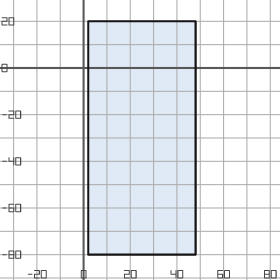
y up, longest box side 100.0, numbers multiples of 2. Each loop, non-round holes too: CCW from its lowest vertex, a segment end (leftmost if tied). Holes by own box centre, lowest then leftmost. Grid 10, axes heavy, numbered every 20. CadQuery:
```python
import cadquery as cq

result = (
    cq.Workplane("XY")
    .moveTo(2.0, -80.0)
    .lineTo(48.0, -80.0)
    .lineTo(48.0, 20.0)
    .lineTo(2.0, 20.0)
    .close()
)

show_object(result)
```